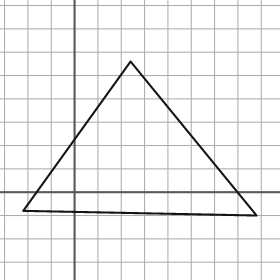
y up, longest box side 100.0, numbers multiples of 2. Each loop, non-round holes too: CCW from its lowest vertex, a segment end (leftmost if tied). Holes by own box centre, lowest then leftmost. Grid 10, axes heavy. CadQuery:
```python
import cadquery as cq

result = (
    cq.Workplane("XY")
    .moveTo(78.0, -10.0)
    .lineTo(24.0, 56.0)
    .lineTo(-22.0, -8.0)
    .close()
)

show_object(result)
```